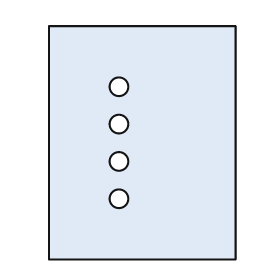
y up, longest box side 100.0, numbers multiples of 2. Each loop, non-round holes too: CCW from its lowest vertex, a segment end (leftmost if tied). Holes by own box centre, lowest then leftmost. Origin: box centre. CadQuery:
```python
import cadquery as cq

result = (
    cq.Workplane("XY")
    .moveTo(-40.0, -50.0)
    .lineTo(40.0, -50.0)
    .lineTo(40.0, 50.0)
    .lineTo(-40.0, 50.0)
    .close()
    .moveTo(-10.0, -24.0)
    .circle(4.0)
    .moveTo(-10.0, -8.0)
    .circle(4.0)
    .moveTo(-10.0, 8.0)
    .circle(4.0)
    .moveTo(-10.0, 24.0)
    .circle(4.0)
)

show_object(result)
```